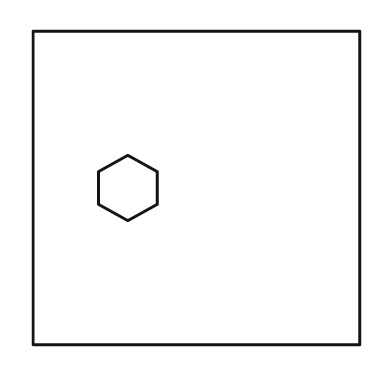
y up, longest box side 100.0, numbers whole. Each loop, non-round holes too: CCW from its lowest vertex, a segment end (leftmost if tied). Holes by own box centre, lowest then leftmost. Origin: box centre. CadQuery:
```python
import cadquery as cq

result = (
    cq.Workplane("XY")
    .moveTo(-50.0, -48.0)
    .lineTo(50.0, -48.0)
    .lineTo(50.0, 48.0)
    .lineTo(-50.0, 48.0)
    .close()
    .moveTo(-21.0, -10.0)
    .lineTo(-12.0, -5.0)
    .lineTo(-12.0, 5.0)
    .lineTo(-21.0, 10.0)
    .lineTo(-30.0, 5.0)
    .lineTo(-30.0, -5.0)
    .close()
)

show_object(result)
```